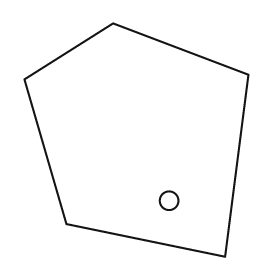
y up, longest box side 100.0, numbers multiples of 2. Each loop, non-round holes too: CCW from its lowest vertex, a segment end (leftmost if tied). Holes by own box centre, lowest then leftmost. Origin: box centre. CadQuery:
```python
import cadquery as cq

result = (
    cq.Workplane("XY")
    .moveTo(38.0, -50.0)
    .lineTo(48.0, 28.0)
    .lineTo(-10.0, 50.0)
    .lineTo(-48.0, 26.0)
    .lineTo(-30.0, -36.0)
    .close()
    .moveTo(14.0, -26.0)
    .circle(4.0)
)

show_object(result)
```